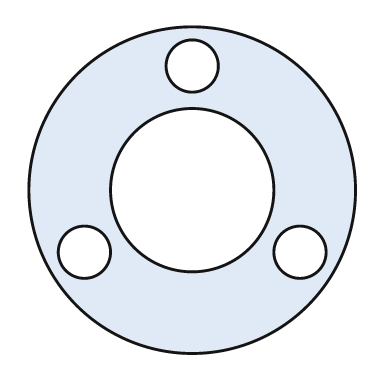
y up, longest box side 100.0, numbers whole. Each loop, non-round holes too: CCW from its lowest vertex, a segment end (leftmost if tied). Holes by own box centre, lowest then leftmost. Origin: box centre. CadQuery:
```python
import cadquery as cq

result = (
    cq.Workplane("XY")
    .moveTo(0.0, 0.0)
    .circle(50.0)
    .moveTo(-33.0, -19.0)
    .circle(8.0)
    .moveTo(33.0, -19.0)
    .circle(8.0)
    .moveTo(0.0, 0.0)
    .circle(25.0)
    .moveTo(0.0, 38.0)
    .circle(8.0)
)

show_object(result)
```